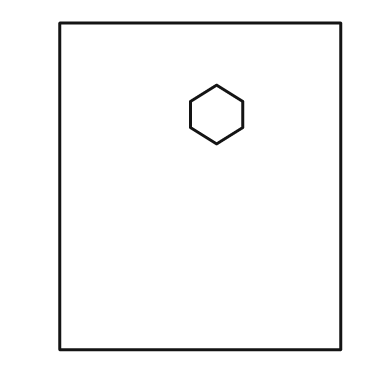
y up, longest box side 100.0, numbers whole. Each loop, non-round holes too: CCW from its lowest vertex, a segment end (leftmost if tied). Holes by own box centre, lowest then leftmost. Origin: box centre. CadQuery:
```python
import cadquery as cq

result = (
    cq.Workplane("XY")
    .moveTo(-43.0, -50.0)
    .lineTo(43.0, -50.0)
    .lineTo(43.0, 50.0)
    .lineTo(-43.0, 50.0)
    .close()
    .moveTo(5.0, 13.0)
    .lineTo(13.0, 18.0)
    .lineTo(13.0, 26.0)
    .lineTo(5.0, 31.0)
    .lineTo(-3.0, 26.0)
    .lineTo(-3.0, 18.0)
    .close()
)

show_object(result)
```